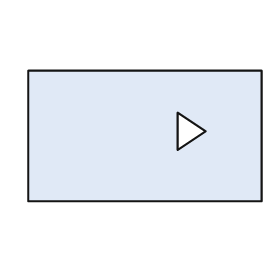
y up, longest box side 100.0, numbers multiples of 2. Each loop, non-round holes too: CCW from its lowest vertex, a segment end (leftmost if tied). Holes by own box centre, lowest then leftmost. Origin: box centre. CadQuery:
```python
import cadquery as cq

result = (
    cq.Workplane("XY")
    .moveTo(-50.0, -28.0)
    .lineTo(50.0, -28.0)
    .lineTo(50.0, 28.0)
    .lineTo(-50.0, 28.0)
    .close()
    .moveTo(14.0, -6.0)
    .lineTo(26.0, 2.0)
    .lineTo(14.0, 10.0)
    .close()
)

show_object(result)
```